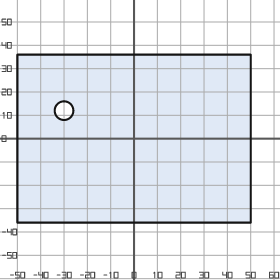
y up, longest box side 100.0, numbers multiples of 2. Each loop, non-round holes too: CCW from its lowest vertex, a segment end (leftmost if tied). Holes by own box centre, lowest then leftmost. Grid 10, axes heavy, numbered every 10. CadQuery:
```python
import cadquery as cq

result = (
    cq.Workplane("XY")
    .moveTo(-50.0, -36.0)
    .lineTo(50.0, -36.0)
    .lineTo(50.0, 36.0)
    .lineTo(-50.0, 36.0)
    .close()
    .moveTo(-30.0, 12.0)
    .circle(4.0)
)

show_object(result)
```